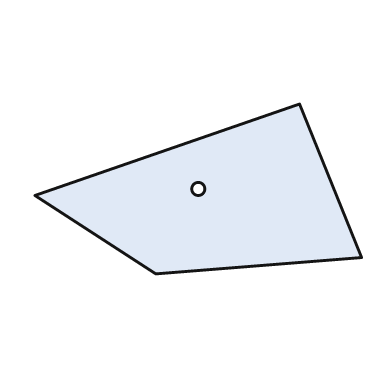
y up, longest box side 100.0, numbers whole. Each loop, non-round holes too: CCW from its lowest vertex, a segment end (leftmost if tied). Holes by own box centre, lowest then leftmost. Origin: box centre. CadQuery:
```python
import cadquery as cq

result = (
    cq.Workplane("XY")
    .moveTo(-13.0, -26.0)
    .lineTo(50.0, -21.0)
    .lineTo(31.0, 26.0)
    .lineTo(-50.0, -2.0)
    .close()
    .moveTo(0.0, 0.0)
    .circle(2.0)
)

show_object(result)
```